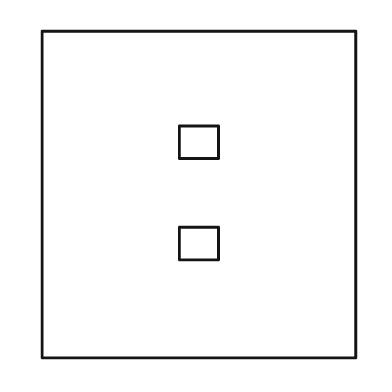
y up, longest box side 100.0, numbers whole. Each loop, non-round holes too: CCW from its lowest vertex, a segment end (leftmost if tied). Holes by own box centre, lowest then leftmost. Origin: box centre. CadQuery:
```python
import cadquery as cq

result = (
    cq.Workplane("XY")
    .moveTo(-48.0, -50.0)
    .lineTo(48.0, -50.0)
    .lineTo(48.0, 50.0)
    .lineTo(-48.0, 50.0)
    .close()
    .moveTo(-6.0, -20.0)
    .lineTo(6.0, -20.0)
    .lineTo(6.0, -10.0)
    .lineTo(-6.0, -10.0)
    .close()
    .moveTo(-6.0, 11.0)
    .lineTo(6.0, 11.0)
    .lineTo(6.0, 21.0)
    .lineTo(-6.0, 21.0)
    .close()
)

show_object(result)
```